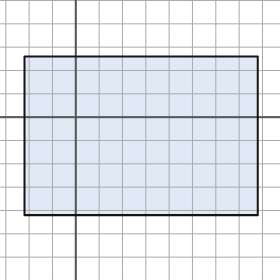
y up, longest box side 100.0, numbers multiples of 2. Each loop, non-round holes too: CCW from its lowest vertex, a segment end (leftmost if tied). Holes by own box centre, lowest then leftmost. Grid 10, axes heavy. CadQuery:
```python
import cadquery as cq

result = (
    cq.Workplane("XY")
    .moveTo(-22.0, -42.0)
    .lineTo(78.0, -42.0)
    .lineTo(78.0, 26.0)
    .lineTo(-22.0, 26.0)
    .close()
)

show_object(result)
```